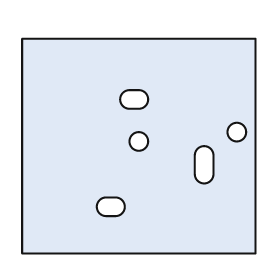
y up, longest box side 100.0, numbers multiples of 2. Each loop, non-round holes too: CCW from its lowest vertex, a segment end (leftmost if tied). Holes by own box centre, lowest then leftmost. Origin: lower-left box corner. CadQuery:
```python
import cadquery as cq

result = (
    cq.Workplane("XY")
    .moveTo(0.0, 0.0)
    .lineTo(100.0, 0.0)
    .lineTo(100.0, 92.0)
    .lineTo(0.0, 92.0)
    .close()
    .moveTo(36.0, 16.0)
    .lineTo(40.0, 16.0)
    .threePointArc((44.0, 20.0), (40.0, 24.0))
    .lineTo(36.0, 24.0)
    .threePointArc((32.0, 20.0), (36.0, 16.0))
    .close()
    .moveTo(74.0, 34.0)
    .threePointArc((78.0, 30.0), (82.0, 34.0))
    .lineTo(82.0, 42.0)
    .threePointArc((78.0, 46.0), (74.0, 42.0))
    .close()
    .moveTo(50.0, 48.0)
    .circle(4.0)
    .moveTo(92.0, 52.0)
    .circle(4.0)
    .moveTo(46.0, 62.0)
    .lineTo(50.0, 62.0)
    .threePointArc((54.0, 66.0), (50.0, 70.0))
    .lineTo(46.0, 70.0)
    .threePointArc((42.0, 66.0), (46.0, 62.0))
    .close()
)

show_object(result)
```